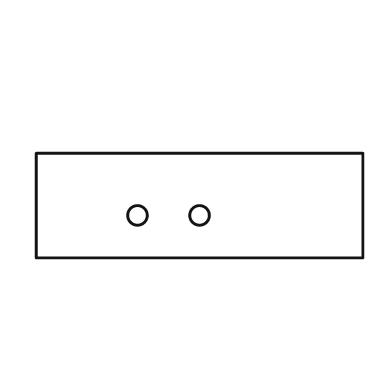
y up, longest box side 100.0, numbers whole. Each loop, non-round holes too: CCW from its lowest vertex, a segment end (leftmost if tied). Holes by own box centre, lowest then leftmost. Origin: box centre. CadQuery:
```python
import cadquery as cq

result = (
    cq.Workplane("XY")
    .moveTo(-50.0, -16.0)
    .lineTo(50.0, -16.0)
    .lineTo(50.0, 16.0)
    .lineTo(-50.0, 16.0)
    .close()
    .moveTo(-19.0, -3.0)
    .circle(3.0)
    .moveTo(0.0, -3.0)
    .circle(3.0)
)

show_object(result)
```